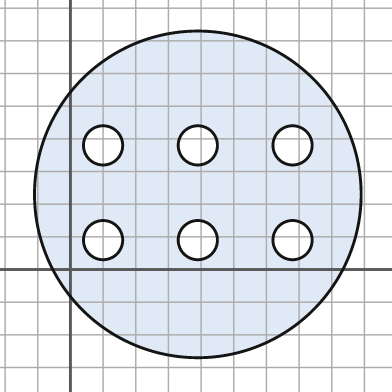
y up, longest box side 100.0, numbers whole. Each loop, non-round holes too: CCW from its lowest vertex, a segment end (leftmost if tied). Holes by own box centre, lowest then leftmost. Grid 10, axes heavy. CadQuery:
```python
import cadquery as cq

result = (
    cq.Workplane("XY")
    .moveTo(39.0, 23.0)
    .circle(50.0)
    .moveTo(10.0, 9.0)
    .circle(6.0)
    .moveTo(39.0, 9.0)
    .circle(6.0)
    .moveTo(68.0, 9.0)
    .circle(6.0)
    .moveTo(10.0, 38.0)
    .circle(6.0)
    .moveTo(39.0, 38.0)
    .circle(6.0)
    .moveTo(68.0, 38.0)
    .circle(6.0)
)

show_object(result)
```